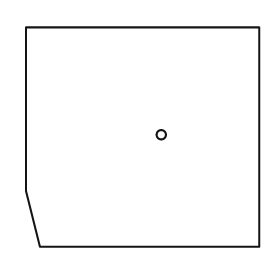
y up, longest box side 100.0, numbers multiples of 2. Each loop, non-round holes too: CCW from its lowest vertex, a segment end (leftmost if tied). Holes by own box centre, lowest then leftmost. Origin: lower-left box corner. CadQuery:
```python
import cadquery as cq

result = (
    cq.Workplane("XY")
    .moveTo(6.0, 0.0)
    .lineTo(100.0, 0.0)
    .lineTo(100.0, 94.0)
    .lineTo(0.0, 94.0)
    .lineTo(0.0, 24.0)
    .close()
    .moveTo(58.0, 48.0)
    .circle(2.0)
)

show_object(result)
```